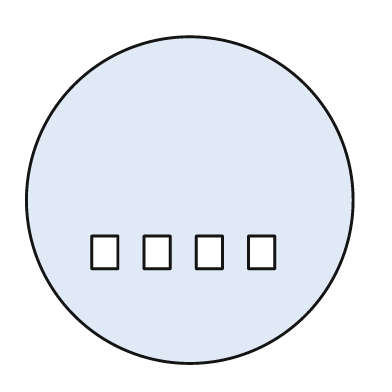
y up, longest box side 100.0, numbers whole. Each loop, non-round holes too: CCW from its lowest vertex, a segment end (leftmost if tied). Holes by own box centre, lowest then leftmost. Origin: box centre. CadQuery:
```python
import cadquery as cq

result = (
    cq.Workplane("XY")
    .moveTo(0.0, 0.0)
    .circle(50.0)
    .moveTo(-30.0, -21.0)
    .lineTo(-22.0, -21.0)
    .lineTo(-22.0, -11.0)
    .lineTo(-30.0, -11.0)
    .close()
    .moveTo(-14.0, -21.0)
    .lineTo(-6.0, -21.0)
    .lineTo(-6.0, -11.0)
    .lineTo(-14.0, -11.0)
    .close()
    .moveTo(2.0, -21.0)
    .lineTo(10.0, -21.0)
    .lineTo(10.0, -11.0)
    .lineTo(2.0, -11.0)
    .close()
    .moveTo(18.0, -21.0)
    .lineTo(26.0, -21.0)
    .lineTo(26.0, -11.0)
    .lineTo(18.0, -11.0)
    .close()
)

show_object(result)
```